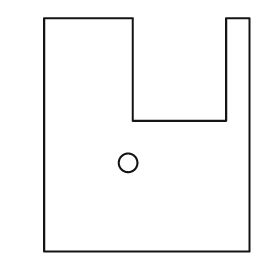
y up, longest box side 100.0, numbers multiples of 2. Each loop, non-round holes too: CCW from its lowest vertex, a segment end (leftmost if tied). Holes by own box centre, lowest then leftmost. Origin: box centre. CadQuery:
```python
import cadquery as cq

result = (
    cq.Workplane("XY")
    .moveTo(-44.0, -50.0)
    .lineTo(44.0, -50.0)
    .lineTo(44.0, 50.0)
    .lineTo(34.0, 50.0)
    .lineTo(34.0, 6.0)
    .lineTo(-6.0, 6.0)
    .lineTo(-6.0, 50.0)
    .lineTo(-44.0, 50.0)
    .close()
    .moveTo(-8.0, -12.0)
    .circle(4.0)
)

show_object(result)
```